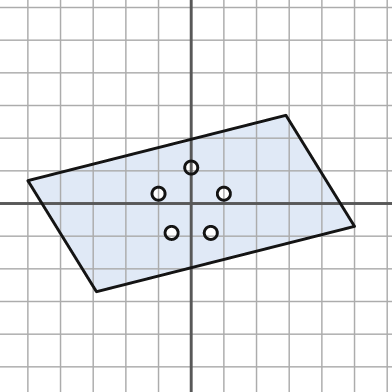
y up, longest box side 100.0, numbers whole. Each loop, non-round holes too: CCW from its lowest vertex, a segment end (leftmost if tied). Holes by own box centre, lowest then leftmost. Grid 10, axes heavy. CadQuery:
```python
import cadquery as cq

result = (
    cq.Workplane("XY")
    .moveTo(-29.0, -27.0)
    .lineTo(50.0, -7.0)
    .lineTo(29.0, 27.0)
    .lineTo(-50.0, 7.0)
    .close()
    .moveTo(-6.0, -9.0)
    .circle(2.0)
    .moveTo(6.0, -9.0)
    .circle(2.0)
    .moveTo(-10.0, 3.0)
    .circle(2.0)
    .moveTo(10.0, 3.0)
    .circle(2.0)
    .moveTo(0.0, 11.0)
    .circle(2.0)
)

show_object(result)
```